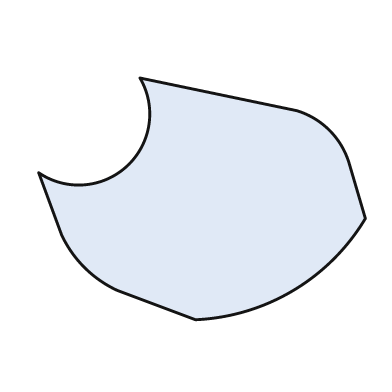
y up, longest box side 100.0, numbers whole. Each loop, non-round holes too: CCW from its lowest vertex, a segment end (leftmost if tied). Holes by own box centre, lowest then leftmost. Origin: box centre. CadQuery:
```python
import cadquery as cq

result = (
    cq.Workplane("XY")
    .moveTo(-2.0, -37.0)
    .threePointArc((28.0, -28.0), (50.0, -6.0))
    .lineTo(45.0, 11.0)
    .threePointArc((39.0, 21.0), (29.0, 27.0))
    .lineTo(-19.0, 37.0)
    .threePointArc((-23.0, 10.0), (-50.0, 8.0))
    .lineTo(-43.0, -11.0)
    .threePointArc((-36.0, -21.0), (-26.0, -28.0))
    .close()
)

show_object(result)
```